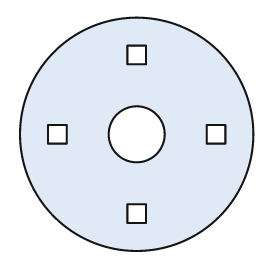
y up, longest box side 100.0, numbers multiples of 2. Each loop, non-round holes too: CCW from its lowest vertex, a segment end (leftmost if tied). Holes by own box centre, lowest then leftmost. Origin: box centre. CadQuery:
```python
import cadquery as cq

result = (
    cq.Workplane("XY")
    .moveTo(0.0, 0.0)
    .circle(50.0)
    .moveTo(-4.0, -38.0)
    .lineTo(4.0, -38.0)
    .lineTo(4.0, -30.0)
    .lineTo(-4.0, -30.0)
    .close()
    .moveTo(-38.0, -4.0)
    .lineTo(-30.0, -4.0)
    .lineTo(-30.0, 4.0)
    .lineTo(-38.0, 4.0)
    .close()
    .moveTo(0.0, 0.0)
    .circle(12.0)
    .moveTo(30.0, -4.0)
    .lineTo(38.0, -4.0)
    .lineTo(38.0, 4.0)
    .lineTo(30.0, 4.0)
    .close()
    .moveTo(-4.0, 30.0)
    .lineTo(4.0, 30.0)
    .lineTo(4.0, 38.0)
    .lineTo(-4.0, 38.0)
    .close()
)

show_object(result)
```